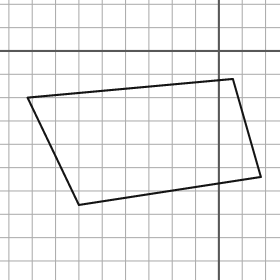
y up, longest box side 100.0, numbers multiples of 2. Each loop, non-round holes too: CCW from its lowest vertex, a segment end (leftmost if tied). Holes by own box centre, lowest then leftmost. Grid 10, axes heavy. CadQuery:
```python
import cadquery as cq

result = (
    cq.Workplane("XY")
    .moveTo(-60.0, -66.0)
    .lineTo(18.0, -54.0)
    .lineTo(6.0, -12.0)
    .lineTo(-82.0, -20.0)
    .close()
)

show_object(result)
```